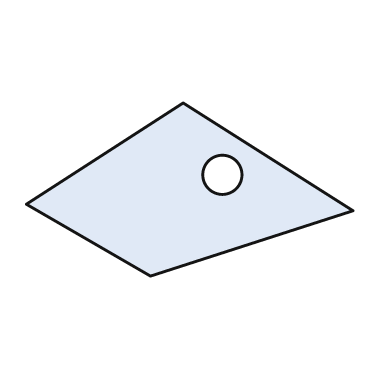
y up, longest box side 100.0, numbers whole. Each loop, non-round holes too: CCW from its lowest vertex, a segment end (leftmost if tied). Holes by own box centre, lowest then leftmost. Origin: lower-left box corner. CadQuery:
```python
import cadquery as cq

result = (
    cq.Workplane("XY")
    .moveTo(38.0, 0.0)
    .lineTo(100.0, 20.0)
    .lineTo(48.0, 53.0)
    .lineTo(0.0, 22.0)
    .close()
    .moveTo(60.0, 31.0)
    .circle(6.0)
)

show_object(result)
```